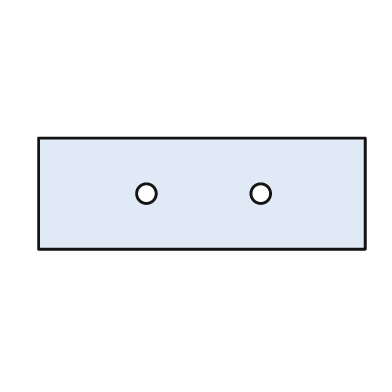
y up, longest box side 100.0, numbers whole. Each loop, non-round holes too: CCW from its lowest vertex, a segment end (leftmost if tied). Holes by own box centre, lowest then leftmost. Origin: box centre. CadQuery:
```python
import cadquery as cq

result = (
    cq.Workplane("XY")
    .moveTo(-50.0, -17.0)
    .lineTo(50.0, -17.0)
    .lineTo(50.0, 17.0)
    .lineTo(-50.0, 17.0)
    .close()
    .moveTo(-17.0, 0.0)
    .circle(3.0)
    .moveTo(18.0, 0.0)
    .circle(3.0)
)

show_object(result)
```